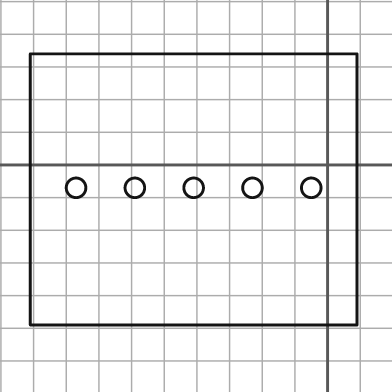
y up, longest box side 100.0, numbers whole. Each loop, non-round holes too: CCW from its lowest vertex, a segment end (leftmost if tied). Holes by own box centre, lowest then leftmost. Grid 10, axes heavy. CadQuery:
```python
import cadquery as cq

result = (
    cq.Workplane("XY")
    .moveTo(-91.0, -49.0)
    .lineTo(9.0, -49.0)
    .lineTo(9.0, 34.0)
    .lineTo(-91.0, 34.0)
    .close()
    .moveTo(-77.0, -7.0)
    .circle(3.0)
    .moveTo(-59.0, -7.0)
    .circle(3.0)
    .moveTo(-41.0, -7.0)
    .circle(3.0)
    .moveTo(-23.0, -7.0)
    .circle(3.0)
    .moveTo(-5.0, -7.0)
    .circle(3.0)
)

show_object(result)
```